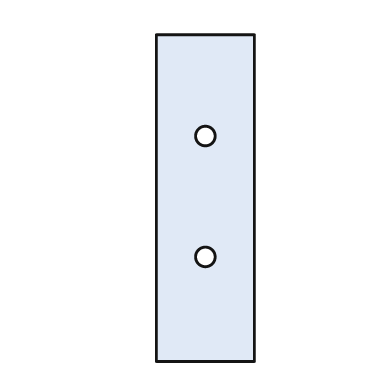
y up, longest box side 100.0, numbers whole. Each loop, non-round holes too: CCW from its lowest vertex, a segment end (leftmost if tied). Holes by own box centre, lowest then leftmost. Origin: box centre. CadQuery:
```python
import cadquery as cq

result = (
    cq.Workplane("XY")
    .moveTo(-15.0, -50.0)
    .lineTo(15.0, -50.0)
    .lineTo(15.0, 50.0)
    .lineTo(-15.0, 50.0)
    .close()
    .moveTo(0.0, -18.0)
    .circle(3.0)
    .moveTo(0.0, 19.0)
    .circle(3.0)
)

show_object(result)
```